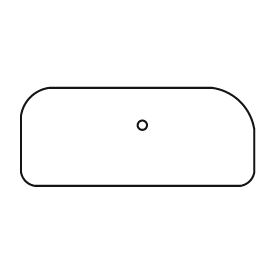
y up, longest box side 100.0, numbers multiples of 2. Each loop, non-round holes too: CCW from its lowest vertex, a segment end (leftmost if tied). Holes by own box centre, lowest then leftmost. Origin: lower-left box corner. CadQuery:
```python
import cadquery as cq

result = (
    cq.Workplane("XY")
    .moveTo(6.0, 0.0)
    .lineTo(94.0, 0.0)
    .threePointArc((98.0, 2.0), (100.0, 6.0))
    .lineTo(100.0, 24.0)
    .threePointArc((94.0, 36.0), (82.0, 42.0))
    .lineTo(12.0, 42.0)
    .threePointArc((4.0, 38.0), (0.0, 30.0))
    .lineTo(0.0, 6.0)
    .threePointArc((2.0, 2.0), (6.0, 0.0))
    .close()
    .moveTo(52.0, 26.0)
    .circle(2.0)
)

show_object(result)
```